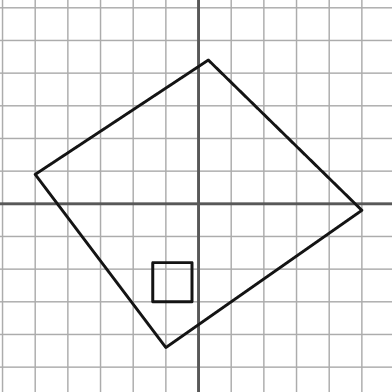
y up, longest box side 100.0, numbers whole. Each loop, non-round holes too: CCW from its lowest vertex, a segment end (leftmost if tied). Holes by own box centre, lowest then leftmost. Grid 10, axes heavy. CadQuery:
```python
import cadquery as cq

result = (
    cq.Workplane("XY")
    .moveTo(-10.0, -44.0)
    .lineTo(50.0, -2.0)
    .lineTo(3.0, 44.0)
    .lineTo(-50.0, 9.0)
    .close()
    .moveTo(-14.0, -30.0)
    .lineTo(-2.0, -30.0)
    .lineTo(-2.0, -18.0)
    .lineTo(-14.0, -18.0)
    .close()
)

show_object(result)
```